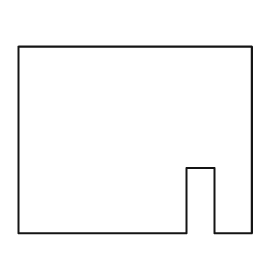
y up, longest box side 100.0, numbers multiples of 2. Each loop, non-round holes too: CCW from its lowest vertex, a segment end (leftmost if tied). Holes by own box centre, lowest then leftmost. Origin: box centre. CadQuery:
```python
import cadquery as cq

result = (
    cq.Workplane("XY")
    .moveTo(-50.0, -40.0)
    .lineTo(22.0, -40.0)
    .lineTo(22.0, -12.0)
    .lineTo(34.0, -12.0)
    .lineTo(34.0, -40.0)
    .lineTo(50.0, -40.0)
    .lineTo(50.0, 40.0)
    .lineTo(-50.0, 40.0)
    .close()
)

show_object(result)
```